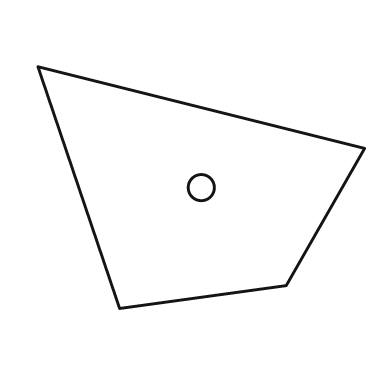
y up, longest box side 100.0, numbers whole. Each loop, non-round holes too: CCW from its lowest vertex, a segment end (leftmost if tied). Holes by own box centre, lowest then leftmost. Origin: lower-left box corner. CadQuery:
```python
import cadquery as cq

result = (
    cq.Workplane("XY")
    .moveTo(25.0, 0.0)
    .lineTo(76.0, 7.0)
    .lineTo(100.0, 49.0)
    .lineTo(0.0, 74.0)
    .close()
    .moveTo(50.0, 37.0)
    .circle(4.0)
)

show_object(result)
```